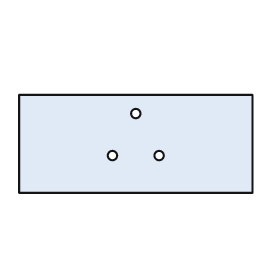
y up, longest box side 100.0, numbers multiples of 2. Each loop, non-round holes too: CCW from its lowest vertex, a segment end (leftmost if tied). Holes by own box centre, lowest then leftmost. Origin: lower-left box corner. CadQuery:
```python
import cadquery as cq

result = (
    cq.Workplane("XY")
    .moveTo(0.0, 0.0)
    .lineTo(100.0, 0.0)
    .lineTo(100.0, 42.0)
    .lineTo(0.0, 42.0)
    .close()
    .moveTo(40.0, 16.0)
    .circle(2.0)
    .moveTo(60.0, 16.0)
    .circle(2.0)
    .moveTo(50.0, 34.0)
    .circle(2.0)
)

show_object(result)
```